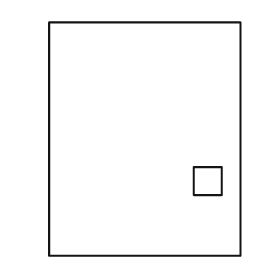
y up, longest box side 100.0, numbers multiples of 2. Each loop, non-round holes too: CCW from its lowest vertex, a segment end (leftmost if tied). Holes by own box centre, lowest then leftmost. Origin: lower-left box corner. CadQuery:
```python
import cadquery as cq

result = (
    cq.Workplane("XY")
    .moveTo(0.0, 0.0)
    .lineTo(82.0, 0.0)
    .lineTo(82.0, 100.0)
    .lineTo(0.0, 100.0)
    .close()
    .moveTo(62.0, 26.0)
    .lineTo(74.0, 26.0)
    .lineTo(74.0, 38.0)
    .lineTo(62.0, 38.0)
    .close()
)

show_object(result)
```